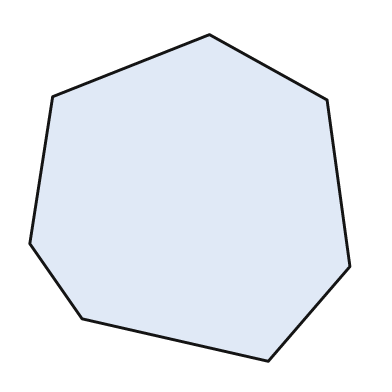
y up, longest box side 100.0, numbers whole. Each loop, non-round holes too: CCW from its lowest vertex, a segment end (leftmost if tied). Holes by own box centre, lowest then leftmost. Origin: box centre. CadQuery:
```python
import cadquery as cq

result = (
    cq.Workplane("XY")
    .moveTo(24.0, -50.0)
    .lineTo(49.0, -21.0)
    .lineTo(42.0, 30.0)
    .lineTo(6.0, 50.0)
    .lineTo(-42.0, 31.0)
    .lineTo(-49.0, -14.0)
    .lineTo(-33.0, -37.0)
    .close()
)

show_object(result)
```